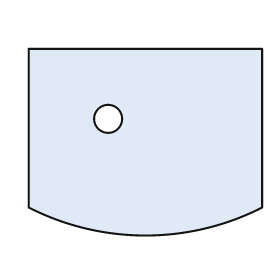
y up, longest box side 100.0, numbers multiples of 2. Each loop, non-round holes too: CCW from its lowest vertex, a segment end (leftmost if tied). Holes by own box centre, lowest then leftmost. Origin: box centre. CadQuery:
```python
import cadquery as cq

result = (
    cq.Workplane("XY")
    .moveTo(-50.0, -28.0)
    .threePointArc((0.0, -40.0), (50.0, -28.0))
    .lineTo(50.0, 40.0)
    .lineTo(-50.0, 40.0)
    .close()
    .moveTo(-16.0, 10.0)
    .circle(6.0)
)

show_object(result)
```